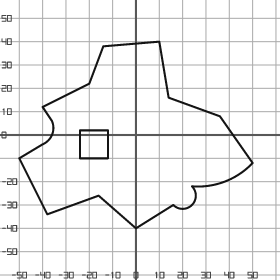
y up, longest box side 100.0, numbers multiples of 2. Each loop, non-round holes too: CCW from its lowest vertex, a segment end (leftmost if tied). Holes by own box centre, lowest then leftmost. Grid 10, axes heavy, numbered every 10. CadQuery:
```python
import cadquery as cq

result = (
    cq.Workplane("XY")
    .moveTo(0.0, -40.0)
    .lineTo(16.0, -30.0)
    .threePointArc((24.0, -30.0), (24.0, -22.0))
    .threePointArc((38.0, -20.0), (50.0, -12.0))
    .lineTo(36.0, 8.0)
    .lineTo(14.0, 16.0)
    .lineTo(10.0, 40.0)
    .lineTo(-14.0, 38.0)
    .lineTo(-20.0, 22.0)
    .lineTo(-40.0, 12.0)
    .lineTo(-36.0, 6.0)
    .threePointArc((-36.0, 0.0), (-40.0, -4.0))
    .lineTo(-50.0, -10.0)
    .lineTo(-38.0, -34.0)
    .lineTo(-16.0, -26.0)
    .close()
    .moveTo(-24.0, -10.0)
    .lineTo(-12.0, -10.0)
    .lineTo(-12.0, 2.0)
    .lineTo(-24.0, 2.0)
    .close()
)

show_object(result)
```